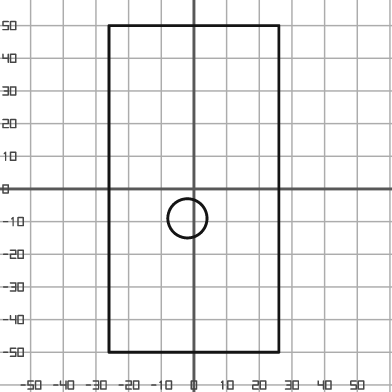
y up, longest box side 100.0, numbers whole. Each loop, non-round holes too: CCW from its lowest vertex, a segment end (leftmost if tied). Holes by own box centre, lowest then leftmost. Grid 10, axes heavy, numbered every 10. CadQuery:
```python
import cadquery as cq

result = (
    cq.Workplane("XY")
    .moveTo(-26.0, -50.0)
    .lineTo(26.0, -50.0)
    .lineTo(26.0, 50.0)
    .lineTo(-26.0, 50.0)
    .close()
    .moveTo(-2.0, -9.0)
    .circle(6.0)
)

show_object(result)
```